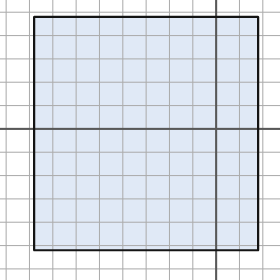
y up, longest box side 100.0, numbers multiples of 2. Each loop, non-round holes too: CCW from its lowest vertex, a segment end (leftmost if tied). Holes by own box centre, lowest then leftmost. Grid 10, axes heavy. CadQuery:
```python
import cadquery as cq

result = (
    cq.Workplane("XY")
    .moveTo(-78.0, -52.0)
    .lineTo(18.0, -52.0)
    .lineTo(18.0, 48.0)
    .lineTo(-78.0, 48.0)
    .close()
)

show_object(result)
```